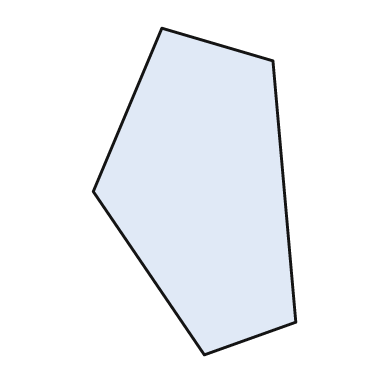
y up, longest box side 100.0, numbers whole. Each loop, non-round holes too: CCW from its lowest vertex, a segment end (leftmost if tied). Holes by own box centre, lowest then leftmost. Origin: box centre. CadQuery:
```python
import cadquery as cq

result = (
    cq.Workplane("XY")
    .moveTo(3.0, -50.0)
    .lineTo(31.0, -40.0)
    .lineTo(24.0, 40.0)
    .lineTo(-10.0, 50.0)
    .lineTo(-31.0, 0.0)
    .close()
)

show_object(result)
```